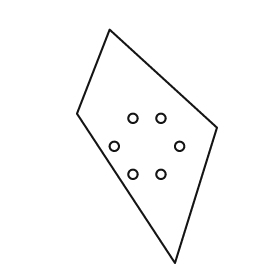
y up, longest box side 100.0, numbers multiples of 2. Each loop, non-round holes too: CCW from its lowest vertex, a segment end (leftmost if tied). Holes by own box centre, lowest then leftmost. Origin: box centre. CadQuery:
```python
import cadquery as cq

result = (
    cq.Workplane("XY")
    .moveTo(12.0, -50.0)
    .lineTo(30.0, 8.0)
    .lineTo(-16.0, 50.0)
    .lineTo(-30.0, 14.0)
    .close()
    .moveTo(-6.0, -12.0)
    .circle(2.0)
    .moveTo(6.0, -12.0)
    .circle(2.0)
    .moveTo(-14.0, 0.0)
    .circle(2.0)
    .moveTo(14.0, 0.0)
    .circle(2.0)
    .moveTo(-6.0, 12.0)
    .circle(2.0)
    .moveTo(6.0, 12.0)
    .circle(2.0)
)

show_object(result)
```